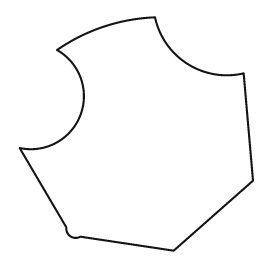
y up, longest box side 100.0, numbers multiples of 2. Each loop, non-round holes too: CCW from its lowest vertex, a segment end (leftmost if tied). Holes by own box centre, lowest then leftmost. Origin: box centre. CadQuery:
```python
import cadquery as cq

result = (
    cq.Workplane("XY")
    .moveTo(16.0, -50.0)
    .lineTo(50.0, -20.0)
    .lineTo(46.0, 26.0)
    .threePointArc((22.0, 30.0), (8.0, 50.0))
    .threePointArc((-14.0, 46.0), (-34.0, 36.0))
    .threePointArc((-24.0, 8.0), (-50.0, -6.0))
    .lineTo(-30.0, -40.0)
    .threePointArc((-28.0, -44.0), (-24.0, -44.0))
    .close()
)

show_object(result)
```